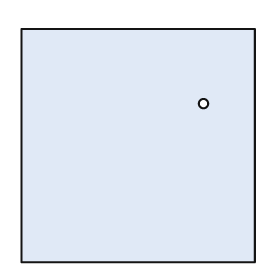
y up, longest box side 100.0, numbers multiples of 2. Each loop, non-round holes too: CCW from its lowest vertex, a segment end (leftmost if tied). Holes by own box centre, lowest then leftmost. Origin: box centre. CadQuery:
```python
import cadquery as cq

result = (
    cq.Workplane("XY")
    .moveTo(-50.0, -50.0)
    .lineTo(50.0, -50.0)
    .lineTo(50.0, 50.0)
    .lineTo(-50.0, 50.0)
    .close()
    .moveTo(28.0, 18.0)
    .circle(2.0)
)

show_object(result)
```